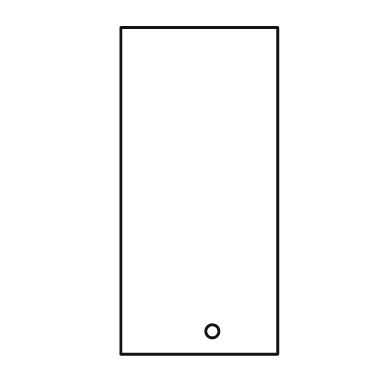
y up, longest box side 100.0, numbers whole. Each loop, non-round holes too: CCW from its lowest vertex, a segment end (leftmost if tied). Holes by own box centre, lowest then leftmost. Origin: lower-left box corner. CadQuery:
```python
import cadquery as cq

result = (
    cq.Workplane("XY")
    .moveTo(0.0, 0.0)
    .lineTo(48.0, 0.0)
    .lineTo(48.0, 100.0)
    .lineTo(0.0, 100.0)
    .close()
    .moveTo(28.0, 7.0)
    .circle(2.0)
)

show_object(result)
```